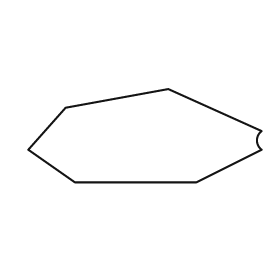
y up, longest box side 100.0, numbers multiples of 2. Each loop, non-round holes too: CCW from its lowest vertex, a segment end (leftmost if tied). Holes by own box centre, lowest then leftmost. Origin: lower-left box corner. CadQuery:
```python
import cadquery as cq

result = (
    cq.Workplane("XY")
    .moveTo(20.0, 0.0)
    .lineTo(72.0, 0.0)
    .lineTo(100.0, 14.0)
    .threePointArc((98.0, 18.0), (100.0, 22.0))
    .lineTo(60.0, 40.0)
    .lineTo(16.0, 32.0)
    .lineTo(0.0, 14.0)
    .close()
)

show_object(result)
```